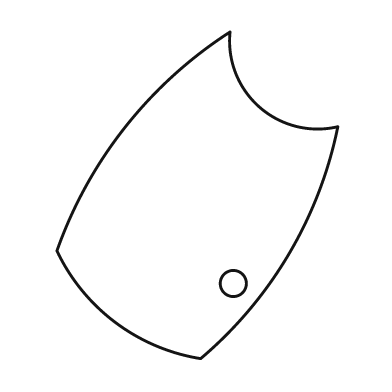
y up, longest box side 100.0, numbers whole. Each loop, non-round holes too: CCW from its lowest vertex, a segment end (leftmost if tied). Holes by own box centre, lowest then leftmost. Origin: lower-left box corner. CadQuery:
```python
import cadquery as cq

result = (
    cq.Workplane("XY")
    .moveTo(44.0, 0.0)
    .threePointArc((71.0, 32.0), (86.0, 71.0))
    .threePointArc((62.0, 77.0), (53.0, 100.0))
    .threePointArc((21.0, 71.0), (0.0, 33.0))
    .threePointArc((18.0, 11.0), (44.0, 0.0))
    .close()
    .moveTo(54.0, 23.0)
    .circle(4.0)
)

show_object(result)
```